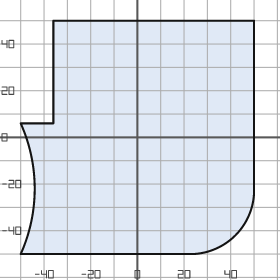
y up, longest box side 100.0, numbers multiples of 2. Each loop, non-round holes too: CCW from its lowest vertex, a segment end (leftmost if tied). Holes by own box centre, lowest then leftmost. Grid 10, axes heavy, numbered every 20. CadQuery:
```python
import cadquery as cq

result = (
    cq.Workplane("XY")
    .moveTo(-50.0, -50.0)
    .lineTo(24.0, -50.0)
    .threePointArc((42.0, -42.0), (50.0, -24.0))
    .lineTo(50.0, 50.0)
    .lineTo(-36.0, 50.0)
    .lineTo(-36.0, 6.0)
    .lineTo(-50.0, 6.0)
    .threePointArc((-44.0, -22.0), (-50.0, -50.0))
    .close()
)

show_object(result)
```